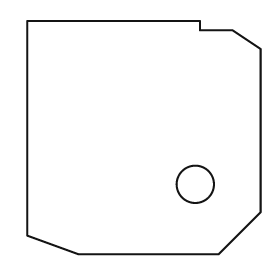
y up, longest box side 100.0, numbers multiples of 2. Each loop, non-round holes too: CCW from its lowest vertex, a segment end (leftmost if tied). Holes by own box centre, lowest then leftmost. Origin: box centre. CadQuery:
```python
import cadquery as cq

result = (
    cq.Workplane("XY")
    .moveTo(-28.0, -50.0)
    .lineTo(32.0, -50.0)
    .lineTo(50.0, -32.0)
    .lineTo(50.0, 38.0)
    .lineTo(38.0, 46.0)
    .lineTo(24.0, 46.0)
    .lineTo(24.0, 50.0)
    .lineTo(-50.0, 50.0)
    .lineTo(-50.0, -42.0)
    .close()
    .moveTo(22.0, -20.0)
    .circle(8.0)
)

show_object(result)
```